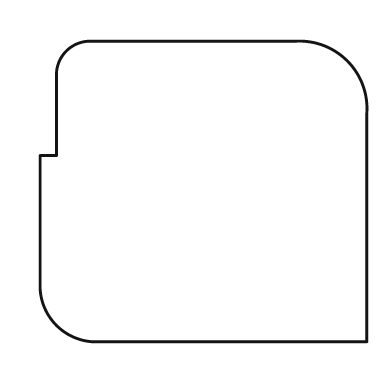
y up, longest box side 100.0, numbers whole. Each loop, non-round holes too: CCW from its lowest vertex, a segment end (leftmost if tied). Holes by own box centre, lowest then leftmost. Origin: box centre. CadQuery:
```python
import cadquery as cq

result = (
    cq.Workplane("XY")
    .moveTo(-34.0, -46.0)
    .lineTo(50.0, -46.0)
    .lineTo(50.0, 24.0)
    .threePointArc((44.0, 40.0), (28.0, 46.0))
    .lineTo(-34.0, 46.0)
    .threePointArc((-42.0, 43.0), (-45.0, 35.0))
    .lineTo(-45.0, 11.0)
    .lineTo(-50.0, 11.0)
    .lineTo(-50.0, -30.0)
    .threePointArc((-45.0, -41.0), (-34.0, -46.0))
    .close()
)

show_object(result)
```